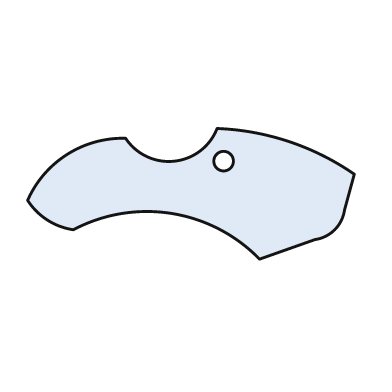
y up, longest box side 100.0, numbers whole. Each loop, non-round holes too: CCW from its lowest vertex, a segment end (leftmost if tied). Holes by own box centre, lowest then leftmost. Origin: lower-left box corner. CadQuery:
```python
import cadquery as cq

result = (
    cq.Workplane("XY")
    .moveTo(71.0, 0.0)
    .lineTo(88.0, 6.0)
    .threePointArc((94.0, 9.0), (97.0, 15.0))
    .lineTo(100.0, 26.0)
    .threePointArc((80.0, 36.0), (58.0, 40.0))
    .threePointArc((45.0, 30.0), (30.0, 37.0))
    .threePointArc((12.0, 32.0), (0.0, 18.0))
    .threePointArc((6.0, 12.0), (14.0, 9.0))
    .threePointArc((44.0, 14.0), (71.0, 0.0))
    .close()
    .moveTo(60.0, 30.0)
    .circle(3.0)
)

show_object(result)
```